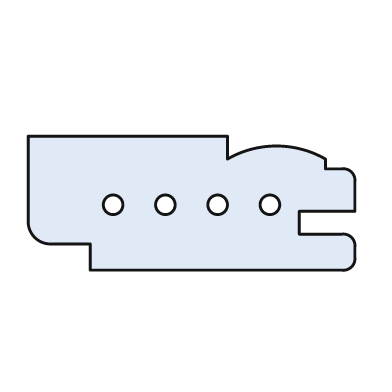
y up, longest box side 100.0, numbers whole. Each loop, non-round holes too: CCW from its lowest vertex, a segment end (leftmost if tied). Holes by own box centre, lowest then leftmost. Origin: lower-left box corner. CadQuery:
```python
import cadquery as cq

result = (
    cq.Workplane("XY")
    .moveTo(19.0, 0.0)
    .lineTo(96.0, 0.0)
    .threePointArc((99.0, 1.0), (100.0, 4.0))
    .lineTo(100.0, 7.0)
    .threePointArc((99.0, 10.0), (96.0, 11.0))
    .lineTo(83.0, 11.0)
    .lineTo(83.0, 18.0)
    .lineTo(100.0, 18.0)
    .lineTo(100.0, 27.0)
    .threePointArc((99.0, 30.0), (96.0, 31.0))
    .lineTo(91.0, 31.0)
    .lineTo(91.0, 34.0)
    .threePointArc((76.0, 38.0), (61.0, 34.0))
    .lineTo(61.0, 41.0)
    .lineTo(0.0, 41.0)
    .lineTo(0.0, 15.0)
    .threePointArc((2.0, 10.0), (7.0, 8.0))
    .lineTo(19.0, 8.0)
    .close()
    .moveTo(26.0, 20.0)
    .circle(3.0)
    .moveTo(42.0, 20.0)
    .circle(3.0)
    .moveTo(58.0, 20.0)
    .circle(3.0)
    .moveTo(74.0, 20.0)
    .circle(3.0)
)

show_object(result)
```